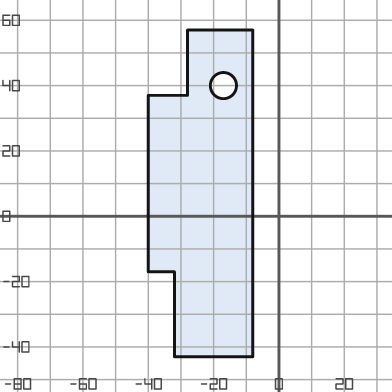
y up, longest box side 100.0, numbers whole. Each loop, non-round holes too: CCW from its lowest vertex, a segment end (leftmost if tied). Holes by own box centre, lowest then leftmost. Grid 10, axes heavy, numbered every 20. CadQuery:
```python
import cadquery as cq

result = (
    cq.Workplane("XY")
    .moveTo(-32.0, -43.0)
    .lineTo(-8.0, -43.0)
    .lineTo(-8.0, 57.0)
    .lineTo(-28.0, 57.0)
    .lineTo(-28.0, 37.0)
    .lineTo(-40.0, 37.0)
    .lineTo(-40.0, -17.0)
    .lineTo(-32.0, -17.0)
    .close()
    .moveTo(-17.0, 40.0)
    .circle(4.0)
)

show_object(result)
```